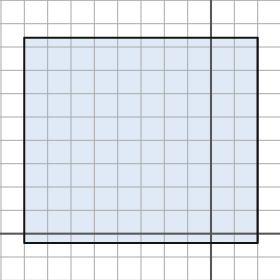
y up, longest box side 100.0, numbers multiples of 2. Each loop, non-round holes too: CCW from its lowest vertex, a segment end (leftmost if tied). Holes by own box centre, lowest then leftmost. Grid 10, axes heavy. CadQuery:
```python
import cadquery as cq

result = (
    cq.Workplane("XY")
    .moveTo(-80.0, -4.0)
    .lineTo(20.0, -4.0)
    .lineTo(20.0, 84.0)
    .lineTo(-80.0, 84.0)
    .close()
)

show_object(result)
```